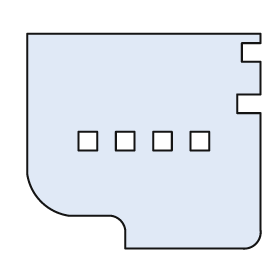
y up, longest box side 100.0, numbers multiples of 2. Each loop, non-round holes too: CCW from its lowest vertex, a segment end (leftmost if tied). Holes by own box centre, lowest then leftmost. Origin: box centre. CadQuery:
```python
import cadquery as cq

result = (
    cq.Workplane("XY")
    .moveTo(-8.0, -46.0)
    .lineTo(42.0, -46.0)
    .threePointArc((48.0, -44.0), (50.0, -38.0))
    .lineTo(50.0, 12.0)
    .lineTo(40.0, 12.0)
    .lineTo(40.0, 20.0)
    .lineTo(50.0, 20.0)
    .lineTo(50.0, 34.0)
    .lineTo(42.0, 34.0)
    .lineTo(42.0, 42.0)
    .lineTo(50.0, 42.0)
    .lineTo(50.0, 46.0)
    .lineTo(-50.0, 46.0)
    .lineTo(-50.0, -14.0)
    .threePointArc((-44.0, -26.0), (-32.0, -32.0))
    .lineTo(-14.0, -32.0)
    .threePointArc((-10.0, -34.0), (-8.0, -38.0))
    .close()
    .moveTo(-28.0, -4.0)
    .lineTo(-20.0, -4.0)
    .lineTo(-20.0, 4.0)
    .lineTo(-28.0, 4.0)
    .close()
    .moveTo(-12.0, -4.0)
    .lineTo(-4.0, -4.0)
    .lineTo(-4.0, 4.0)
    .lineTo(-12.0, 4.0)
    .close()
    .moveTo(4.0, -4.0)
    .lineTo(12.0, -4.0)
    .lineTo(12.0, 4.0)
    .lineTo(4.0, 4.0)
    .close()
    .moveTo(20.0, -4.0)
    .lineTo(28.0, -4.0)
    .lineTo(28.0, 4.0)
    .lineTo(20.0, 4.0)
    .close()
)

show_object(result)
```